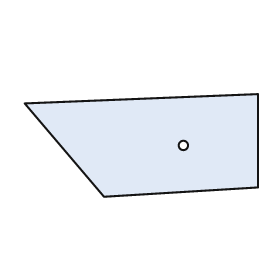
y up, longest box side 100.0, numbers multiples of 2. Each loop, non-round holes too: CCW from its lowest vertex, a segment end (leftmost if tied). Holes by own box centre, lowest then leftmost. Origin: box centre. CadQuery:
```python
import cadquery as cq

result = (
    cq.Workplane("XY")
    .moveTo(-16.0, -22.0)
    .lineTo(50.0, -18.0)
    .lineTo(50.0, 22.0)
    .lineTo(-50.0, 18.0)
    .close()
    .moveTo(18.0, 0.0)
    .circle(2.0)
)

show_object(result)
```